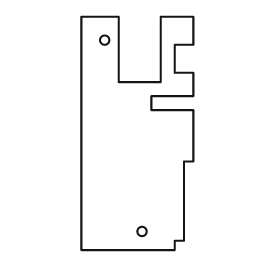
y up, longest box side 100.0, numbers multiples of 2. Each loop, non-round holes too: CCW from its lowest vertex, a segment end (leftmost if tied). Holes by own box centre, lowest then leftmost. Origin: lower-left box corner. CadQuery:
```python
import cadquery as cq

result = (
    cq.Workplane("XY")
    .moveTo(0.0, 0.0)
    .lineTo(40.0, 0.0)
    .lineTo(40.0, 4.0)
    .lineTo(44.0, 4.0)
    .lineTo(44.0, 38.0)
    .lineTo(48.0, 38.0)
    .lineTo(48.0, 60.0)
    .lineTo(30.0, 60.0)
    .lineTo(30.0, 66.0)
    .lineTo(48.0, 66.0)
    .lineTo(48.0, 76.0)
    .lineTo(40.0, 76.0)
    .lineTo(40.0, 88.0)
    .lineTo(48.0, 88.0)
    .lineTo(48.0, 100.0)
    .lineTo(34.0, 100.0)
    .lineTo(34.0, 72.0)
    .lineTo(16.0, 72.0)
    .lineTo(16.0, 100.0)
    .lineTo(0.0, 100.0)
    .close()
    .moveTo(26.0, 8.0)
    .circle(2.0)
    .moveTo(10.0, 90.0)
    .circle(2.0)
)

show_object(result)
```